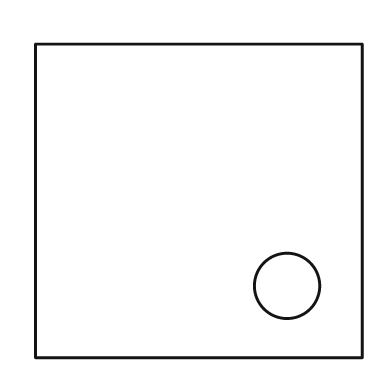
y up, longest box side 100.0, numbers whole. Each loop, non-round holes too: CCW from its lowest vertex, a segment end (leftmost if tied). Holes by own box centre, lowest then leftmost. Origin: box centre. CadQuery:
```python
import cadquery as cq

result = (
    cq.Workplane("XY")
    .moveTo(-50.0, -48.0)
    .lineTo(50.0, -48.0)
    .lineTo(50.0, 48.0)
    .lineTo(-50.0, 48.0)
    .close()
    .moveTo(27.0, -26.0)
    .circle(10.0)
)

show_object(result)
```